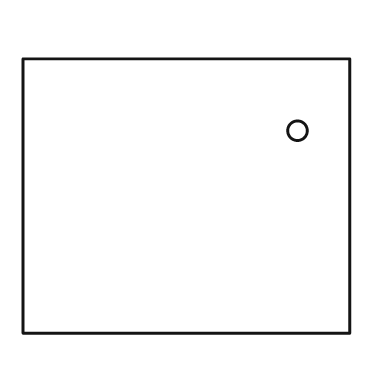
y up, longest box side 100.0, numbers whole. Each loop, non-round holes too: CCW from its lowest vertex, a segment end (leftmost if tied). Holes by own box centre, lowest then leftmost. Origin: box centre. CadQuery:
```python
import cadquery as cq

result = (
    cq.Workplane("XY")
    .moveTo(-50.0, -42.0)
    .lineTo(50.0, -42.0)
    .lineTo(50.0, 42.0)
    .lineTo(-50.0, 42.0)
    .close()
    .moveTo(34.0, 20.0)
    .circle(3.0)
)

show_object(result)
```